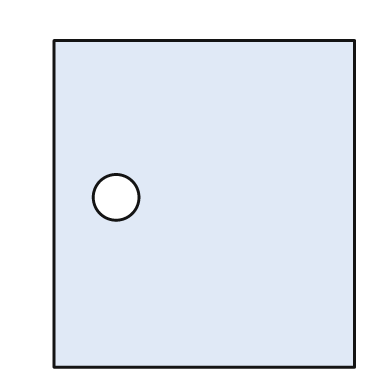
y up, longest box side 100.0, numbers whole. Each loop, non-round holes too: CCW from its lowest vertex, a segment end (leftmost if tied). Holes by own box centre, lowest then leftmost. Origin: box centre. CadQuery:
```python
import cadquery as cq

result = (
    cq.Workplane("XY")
    .moveTo(-46.0, -50.0)
    .lineTo(46.0, -50.0)
    .lineTo(46.0, 50.0)
    .lineTo(-46.0, 50.0)
    .close()
    .moveTo(-27.0, 2.0)
    .circle(7.0)
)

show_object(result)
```